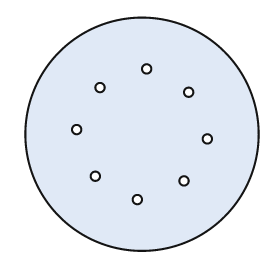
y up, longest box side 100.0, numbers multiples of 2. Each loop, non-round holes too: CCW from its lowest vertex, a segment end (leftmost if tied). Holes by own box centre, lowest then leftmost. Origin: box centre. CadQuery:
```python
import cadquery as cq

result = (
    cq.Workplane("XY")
    .moveTo(0.0, 0.0)
    .circle(50.0)
    .moveTo(-2.0, -28.0)
    .circle(2.0)
    .moveTo(18.0, -20.0)
    .circle(2.0)
    .moveTo(-20.0, -18.0)
    .circle(2.0)
    .moveTo(28.0, -2.0)
    .circle(2.0)
    .moveTo(-28.0, 2.0)
    .circle(2.0)
    .moveTo(20.0, 18.0)
    .circle(2.0)
    .moveTo(-18.0, 20.0)
    .circle(2.0)
    .moveTo(2.0, 28.0)
    .circle(2.0)
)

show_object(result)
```